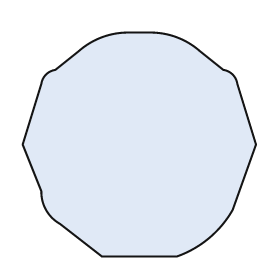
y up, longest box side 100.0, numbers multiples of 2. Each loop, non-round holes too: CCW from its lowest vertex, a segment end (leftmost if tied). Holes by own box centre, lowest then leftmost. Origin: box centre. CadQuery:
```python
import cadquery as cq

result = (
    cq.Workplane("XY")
    .moveTo(-16.0, -48.0)
    .lineTo(16.0, -48.0)
    .threePointArc((30.0, -40.0), (40.0, -28.0))
    .lineTo(50.0, 0.0)
    .lineTo(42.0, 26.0)
    .threePointArc((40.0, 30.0), (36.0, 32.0))
    .lineTo(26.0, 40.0)
    .threePointArc((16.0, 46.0), (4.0, 48.0))
    .lineTo(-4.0, 48.0)
    .threePointArc((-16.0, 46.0), (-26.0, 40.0))
    .lineTo(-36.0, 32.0)
    .threePointArc((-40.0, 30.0), (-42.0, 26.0))
    .lineTo(-50.0, 0.0)
    .lineTo(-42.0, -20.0)
    .threePointArc((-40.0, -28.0), (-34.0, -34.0))
    .close()
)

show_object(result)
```